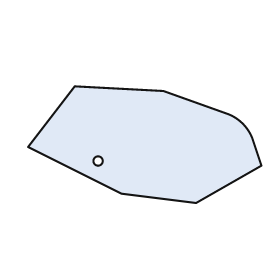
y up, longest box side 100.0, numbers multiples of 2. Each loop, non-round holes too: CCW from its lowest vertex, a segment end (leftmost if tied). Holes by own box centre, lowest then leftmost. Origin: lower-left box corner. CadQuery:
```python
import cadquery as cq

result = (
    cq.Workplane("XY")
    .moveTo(72.0, 0.0)
    .lineTo(100.0, 16.0)
    .lineTo(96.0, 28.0)
    .threePointArc((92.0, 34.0), (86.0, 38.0))
    .lineTo(58.0, 48.0)
    .lineTo(20.0, 50.0)
    .lineTo(0.0, 24.0)
    .lineTo(40.0, 4.0)
    .close()
    .moveTo(30.0, 18.0)
    .circle(2.0)
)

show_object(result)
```